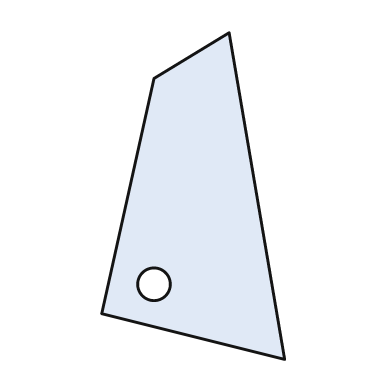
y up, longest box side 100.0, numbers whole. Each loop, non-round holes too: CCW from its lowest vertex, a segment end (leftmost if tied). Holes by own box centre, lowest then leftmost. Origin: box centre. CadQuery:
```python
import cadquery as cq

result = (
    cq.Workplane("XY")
    .moveTo(28.0, -50.0)
    .lineTo(11.0, 50.0)
    .lineTo(-12.0, 36.0)
    .lineTo(-28.0, -36.0)
    .close()
    .moveTo(-12.0, -27.0)
    .circle(5.0)
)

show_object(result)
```